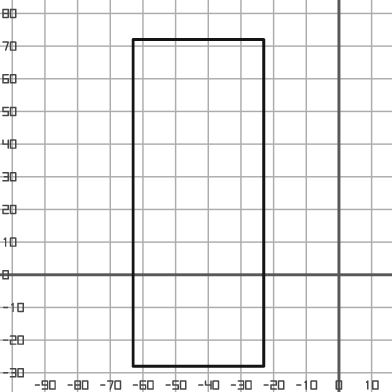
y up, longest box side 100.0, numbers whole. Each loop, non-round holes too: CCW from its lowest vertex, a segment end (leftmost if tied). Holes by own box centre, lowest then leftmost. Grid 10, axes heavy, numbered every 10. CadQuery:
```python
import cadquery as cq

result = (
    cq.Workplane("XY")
    .moveTo(-63.0, -28.0)
    .lineTo(-23.0, -28.0)
    .lineTo(-23.0, 72.0)
    .lineTo(-63.0, 72.0)
    .close()
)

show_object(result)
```